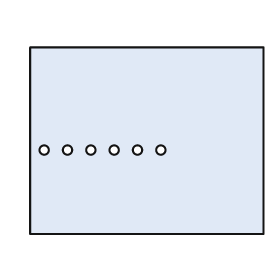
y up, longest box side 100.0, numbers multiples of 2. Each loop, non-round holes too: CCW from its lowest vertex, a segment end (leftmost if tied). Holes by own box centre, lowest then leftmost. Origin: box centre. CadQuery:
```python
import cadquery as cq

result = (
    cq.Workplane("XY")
    .moveTo(-50.0, -40.0)
    .lineTo(50.0, -40.0)
    .lineTo(50.0, 40.0)
    .lineTo(-50.0, 40.0)
    .close()
    .moveTo(-44.0, -4.0)
    .circle(2.0)
    .moveTo(-34.0, -4.0)
    .circle(2.0)
    .moveTo(-24.0, -4.0)
    .circle(2.0)
    .moveTo(-14.0, -4.0)
    .circle(2.0)
    .moveTo(-4.0, -4.0)
    .circle(2.0)
    .moveTo(6.0, -4.0)
    .circle(2.0)
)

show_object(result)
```